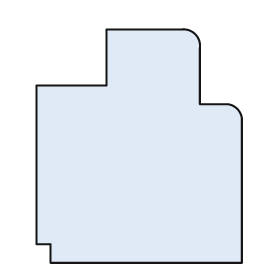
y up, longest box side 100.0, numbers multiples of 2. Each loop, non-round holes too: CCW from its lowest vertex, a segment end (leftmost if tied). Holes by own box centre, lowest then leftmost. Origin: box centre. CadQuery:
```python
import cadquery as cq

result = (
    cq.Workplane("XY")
    .moveTo(-38.0, -50.0)
    .lineTo(44.0, -50.0)
    .lineTo(44.0, 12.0)
    .threePointArc((42.0, 16.0), (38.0, 18.0))
    .lineTo(26.0, 18.0)
    .lineTo(26.0, 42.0)
    .threePointArc((24.0, 48.0), (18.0, 50.0))
    .lineTo(-14.0, 50.0)
    .lineTo(-14.0, 26.0)
    .lineTo(-44.0, 26.0)
    .lineTo(-44.0, -42.0)
    .lineTo(-38.0, -42.0)
    .close()
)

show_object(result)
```